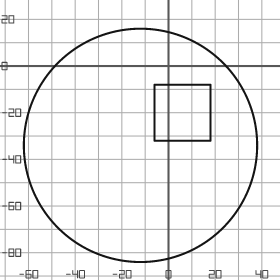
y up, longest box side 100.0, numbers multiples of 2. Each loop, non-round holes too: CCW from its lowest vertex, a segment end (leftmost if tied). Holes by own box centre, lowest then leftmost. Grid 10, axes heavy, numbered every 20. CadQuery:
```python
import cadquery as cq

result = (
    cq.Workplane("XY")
    .moveTo(-12.0, -34.0)
    .circle(50.0)
    .moveTo(-6.0, -32.0)
    .lineTo(18.0, -32.0)
    .lineTo(18.0, -8.0)
    .lineTo(-6.0, -8.0)
    .close()
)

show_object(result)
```